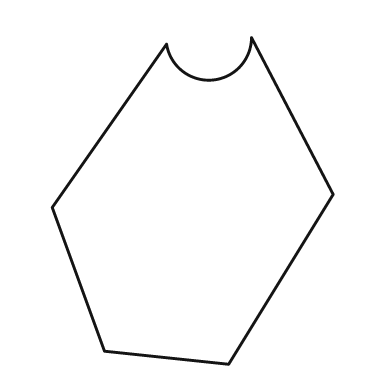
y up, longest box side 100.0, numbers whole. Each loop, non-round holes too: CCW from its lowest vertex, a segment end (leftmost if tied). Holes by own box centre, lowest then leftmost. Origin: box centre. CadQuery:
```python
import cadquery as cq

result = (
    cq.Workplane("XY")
    .moveTo(11.0, -50.0)
    .lineTo(43.0, 2.0)
    .lineTo(18.0, 50.0)
    .threePointArc((6.0, 37.0), (-8.0, 48.0))
    .lineTo(-43.0, -2.0)
    .lineTo(-27.0, -46.0)
    .close()
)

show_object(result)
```